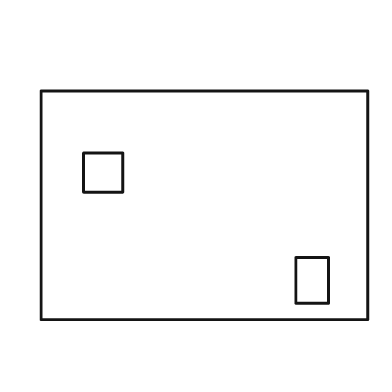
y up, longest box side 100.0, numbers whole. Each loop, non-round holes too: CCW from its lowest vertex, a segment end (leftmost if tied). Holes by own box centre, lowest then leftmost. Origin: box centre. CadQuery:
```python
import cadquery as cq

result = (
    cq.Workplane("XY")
    .moveTo(-50.0, -35.0)
    .lineTo(50.0, -35.0)
    .lineTo(50.0, 35.0)
    .lineTo(-50.0, 35.0)
    .close()
    .moveTo(28.0, -30.0)
    .lineTo(38.0, -30.0)
    .lineTo(38.0, -16.0)
    .lineTo(28.0, -16.0)
    .close()
    .moveTo(-37.0, 4.0)
    .lineTo(-25.0, 4.0)
    .lineTo(-25.0, 16.0)
    .lineTo(-37.0, 16.0)
    .close()
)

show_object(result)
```